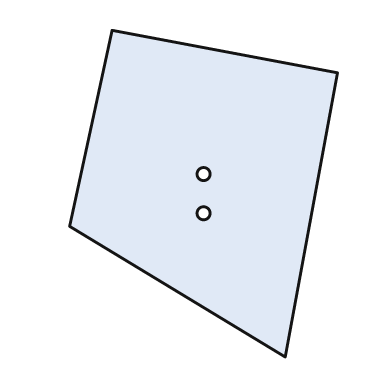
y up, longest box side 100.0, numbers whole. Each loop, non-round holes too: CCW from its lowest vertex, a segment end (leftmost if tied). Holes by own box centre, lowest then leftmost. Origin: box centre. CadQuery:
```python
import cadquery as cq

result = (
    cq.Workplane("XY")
    .moveTo(25.0, -50.0)
    .lineTo(41.0, 37.0)
    .lineTo(-28.0, 50.0)
    .lineTo(-41.0, -10.0)
    .close()
    .moveTo(0.0, -6.0)
    .circle(2.0)
    .moveTo(0.0, 6.0)
    .circle(2.0)
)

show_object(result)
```